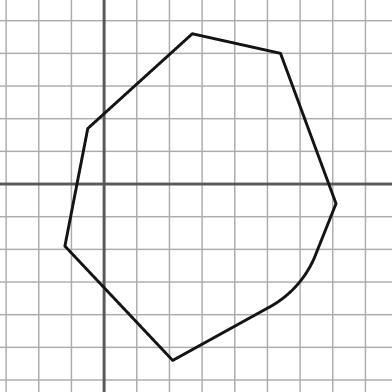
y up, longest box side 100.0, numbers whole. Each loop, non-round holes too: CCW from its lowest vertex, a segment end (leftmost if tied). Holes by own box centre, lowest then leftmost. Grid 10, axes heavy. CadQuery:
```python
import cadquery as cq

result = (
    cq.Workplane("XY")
    .moveTo(21.0, -54.0)
    .lineTo(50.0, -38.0)
    .threePointArc((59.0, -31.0), (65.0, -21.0))
    .lineTo(71.0, -6.0)
    .lineTo(54.0, 40.0)
    .lineTo(27.0, 46.0)
    .lineTo(-5.0, 17.0)
    .lineTo(-12.0, -19.0)
    .close()
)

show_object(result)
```